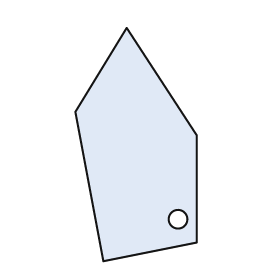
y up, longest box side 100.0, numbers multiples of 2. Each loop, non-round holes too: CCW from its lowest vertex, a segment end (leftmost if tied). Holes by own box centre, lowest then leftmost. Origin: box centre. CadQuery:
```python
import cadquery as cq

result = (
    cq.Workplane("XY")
    .moveTo(-14.0, -50.0)
    .lineTo(26.0, -42.0)
    .lineTo(26.0, 4.0)
    .lineTo(-4.0, 50.0)
    .lineTo(-26.0, 14.0)
    .close()
    .moveTo(18.0, -32.0)
    .circle(4.0)
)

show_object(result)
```